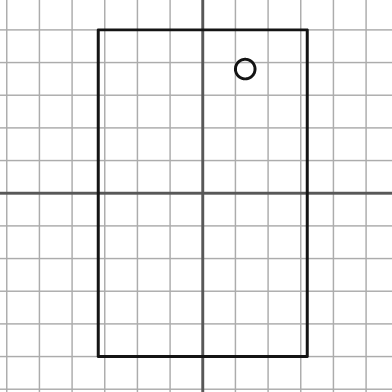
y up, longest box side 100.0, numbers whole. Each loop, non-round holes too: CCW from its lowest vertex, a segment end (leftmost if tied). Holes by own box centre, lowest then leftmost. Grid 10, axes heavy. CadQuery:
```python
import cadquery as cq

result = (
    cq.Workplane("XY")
    .moveTo(-32.0, -50.0)
    .lineTo(32.0, -50.0)
    .lineTo(32.0, 50.0)
    .lineTo(-32.0, 50.0)
    .close()
    .moveTo(13.0, 38.0)
    .circle(3.0)
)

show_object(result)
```